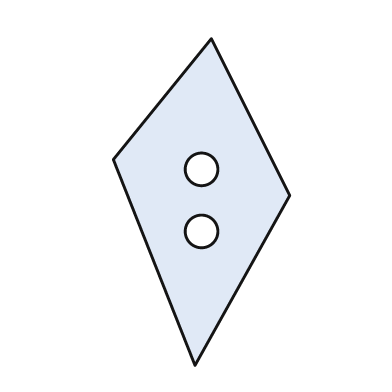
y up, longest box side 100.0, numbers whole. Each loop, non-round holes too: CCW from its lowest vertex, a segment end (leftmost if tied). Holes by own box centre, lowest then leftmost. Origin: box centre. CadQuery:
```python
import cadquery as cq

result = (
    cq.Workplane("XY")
    .moveTo(-2.0, -50.0)
    .lineTo(27.0, 2.0)
    .lineTo(3.0, 50.0)
    .lineTo(-27.0, 13.0)
    .close()
    .moveTo(0.0, -9.0)
    .circle(5.0)
    .moveTo(0.0, 10.0)
    .circle(5.0)
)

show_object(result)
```